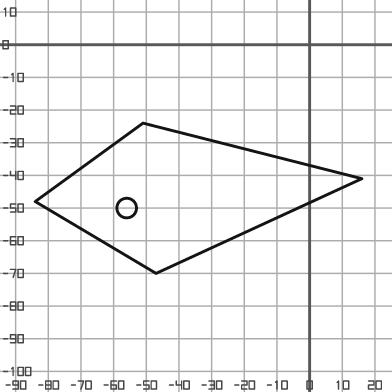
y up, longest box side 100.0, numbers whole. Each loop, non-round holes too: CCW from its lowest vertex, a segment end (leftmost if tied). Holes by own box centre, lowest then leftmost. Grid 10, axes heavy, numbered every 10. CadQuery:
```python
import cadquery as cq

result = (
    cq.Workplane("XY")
    .moveTo(-47.0, -70.0)
    .lineTo(16.0, -41.0)
    .lineTo(-51.0, -24.0)
    .lineTo(-84.0, -48.0)
    .close()
    .moveTo(-56.0, -50.0)
    .circle(3.0)
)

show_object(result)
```